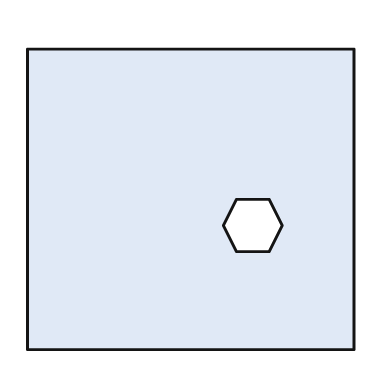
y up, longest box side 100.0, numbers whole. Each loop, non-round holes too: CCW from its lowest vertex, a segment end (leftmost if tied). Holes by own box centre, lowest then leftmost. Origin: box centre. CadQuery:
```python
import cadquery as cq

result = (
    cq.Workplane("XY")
    .moveTo(-50.0, -46.0)
    .lineTo(50.0, -46.0)
    .lineTo(50.0, 46.0)
    .lineTo(-50.0, 46.0)
    .close()
    .moveTo(14.0, -16.0)
    .lineTo(24.0, -16.0)
    .lineTo(28.0, -8.0)
    .lineTo(24.0, 0.0)
    .lineTo(14.0, 0.0)
    .lineTo(10.0, -8.0)
    .close()
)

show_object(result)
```